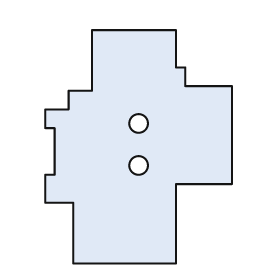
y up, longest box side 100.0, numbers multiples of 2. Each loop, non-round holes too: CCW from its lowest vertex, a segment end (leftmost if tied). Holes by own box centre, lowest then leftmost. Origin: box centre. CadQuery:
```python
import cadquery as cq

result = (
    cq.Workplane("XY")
    .moveTo(-28.0, -50.0)
    .lineTo(16.0, -50.0)
    .lineTo(16.0, -16.0)
    .lineTo(40.0, -16.0)
    .lineTo(40.0, 26.0)
    .lineTo(20.0, 26.0)
    .lineTo(20.0, 34.0)
    .lineTo(16.0, 34.0)
    .lineTo(16.0, 50.0)
    .lineTo(-20.0, 50.0)
    .lineTo(-20.0, 24.0)
    .lineTo(-30.0, 24.0)
    .lineTo(-30.0, 16.0)
    .lineTo(-40.0, 16.0)
    .lineTo(-40.0, 8.0)
    .lineTo(-36.0, 8.0)
    .lineTo(-36.0, -12.0)
    .lineTo(-40.0, -12.0)
    .lineTo(-40.0, -24.0)
    .lineTo(-28.0, -24.0)
    .close()
    .moveTo(0.0, -8.0)
    .circle(4.0)
    .moveTo(0.0, 10.0)
    .circle(4.0)
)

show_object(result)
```